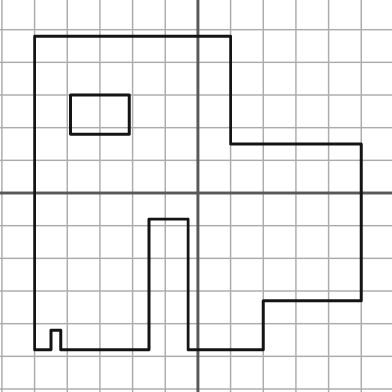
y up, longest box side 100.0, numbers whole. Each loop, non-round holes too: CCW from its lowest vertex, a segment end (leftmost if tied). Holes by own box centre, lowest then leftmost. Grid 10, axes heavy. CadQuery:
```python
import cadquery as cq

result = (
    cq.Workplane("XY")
    .moveTo(-50.0, -48.0)
    .lineTo(-45.0, -48.0)
    .lineTo(-45.0, -42.0)
    .lineTo(-42.0, -42.0)
    .lineTo(-42.0, -48.0)
    .lineTo(-15.0, -48.0)
    .lineTo(-15.0, -8.0)
    .lineTo(-3.0, -8.0)
    .lineTo(-3.0, -48.0)
    .lineTo(20.0, -48.0)
    .lineTo(20.0, -33.0)
    .lineTo(50.0, -33.0)
    .lineTo(50.0, 15.0)
    .lineTo(10.0, 15.0)
    .lineTo(10.0, 48.0)
    .lineTo(-50.0, 48.0)
    .close()
    .moveTo(-39.0, 18.0)
    .lineTo(-21.0, 18.0)
    .lineTo(-21.0, 30.0)
    .lineTo(-39.0, 30.0)
    .close()
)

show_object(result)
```